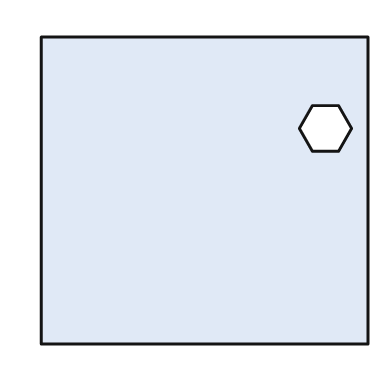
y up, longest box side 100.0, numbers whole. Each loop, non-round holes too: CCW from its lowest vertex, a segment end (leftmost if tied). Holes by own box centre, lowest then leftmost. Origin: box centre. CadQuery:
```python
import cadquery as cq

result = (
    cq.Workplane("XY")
    .moveTo(-50.0, -47.0)
    .lineTo(50.0, -47.0)
    .lineTo(50.0, 47.0)
    .lineTo(-50.0, 47.0)
    .close()
    .moveTo(33.0, 12.0)
    .lineTo(41.0, 12.0)
    .lineTo(45.0, 19.0)
    .lineTo(41.0, 26.0)
    .lineTo(33.0, 26.0)
    .lineTo(29.0, 19.0)
    .close()
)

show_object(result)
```